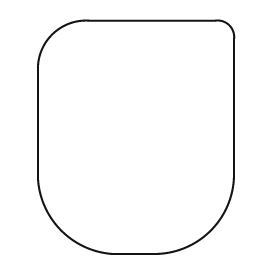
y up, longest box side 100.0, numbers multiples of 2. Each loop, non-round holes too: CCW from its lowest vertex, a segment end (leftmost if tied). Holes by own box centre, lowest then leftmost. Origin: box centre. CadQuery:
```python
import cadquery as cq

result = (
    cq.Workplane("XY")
    .moveTo(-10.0, -50.0)
    .lineTo(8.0, -50.0)
    .threePointArc((32.0, -40.0), (42.0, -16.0))
    .lineTo(42.0, 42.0)
    .threePointArc((40.0, 48.0), (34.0, 50.0))
    .lineTo(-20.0, 50.0)
    .threePointArc((-36.0, 44.0), (-42.0, 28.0))
    .lineTo(-42.0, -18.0)
    .threePointArc((-32.0, -40.0), (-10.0, -50.0))
    .close()
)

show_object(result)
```